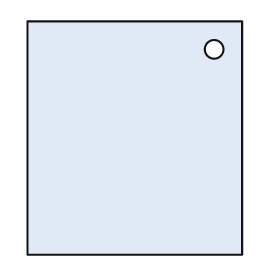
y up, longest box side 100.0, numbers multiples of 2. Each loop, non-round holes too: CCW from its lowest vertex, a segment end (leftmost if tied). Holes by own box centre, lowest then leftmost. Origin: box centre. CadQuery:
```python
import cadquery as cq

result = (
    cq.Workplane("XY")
    .moveTo(-46.0, -50.0)
    .lineTo(46.0, -50.0)
    .lineTo(46.0, 50.0)
    .lineTo(-46.0, 50.0)
    .close()
    .moveTo(34.0, 38.0)
    .circle(4.0)
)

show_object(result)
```